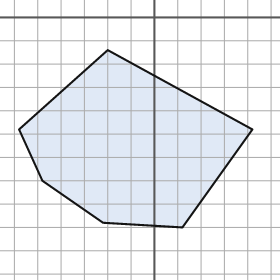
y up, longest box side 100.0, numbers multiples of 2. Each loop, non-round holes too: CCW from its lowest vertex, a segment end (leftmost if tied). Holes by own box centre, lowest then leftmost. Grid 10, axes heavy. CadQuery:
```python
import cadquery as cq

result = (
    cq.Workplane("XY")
    .moveTo(12.0, -90.0)
    .lineTo(42.0, -48.0)
    .lineTo(-20.0, -14.0)
    .lineTo(-58.0, -48.0)
    .lineTo(-48.0, -70.0)
    .lineTo(-22.0, -88.0)
    .close()
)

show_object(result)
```